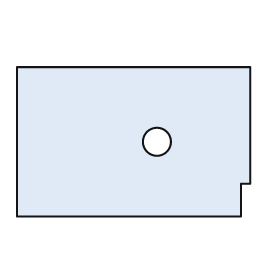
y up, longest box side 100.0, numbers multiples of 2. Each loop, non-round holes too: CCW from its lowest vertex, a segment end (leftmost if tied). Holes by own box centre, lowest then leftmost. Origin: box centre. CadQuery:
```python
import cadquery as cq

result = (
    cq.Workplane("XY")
    .moveTo(-50.0, -32.0)
    .lineTo(46.0, -32.0)
    .lineTo(46.0, -18.0)
    .lineTo(50.0, -18.0)
    .lineTo(50.0, 32.0)
    .lineTo(-50.0, 32.0)
    .close()
    .moveTo(10.0, 0.0)
    .circle(6.0)
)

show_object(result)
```